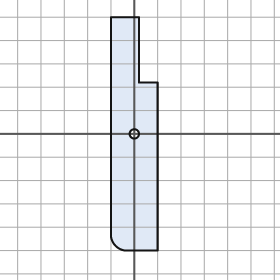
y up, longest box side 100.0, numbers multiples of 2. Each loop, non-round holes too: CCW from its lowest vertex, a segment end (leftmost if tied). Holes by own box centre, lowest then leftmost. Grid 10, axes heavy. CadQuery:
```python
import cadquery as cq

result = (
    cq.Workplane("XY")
    .moveTo(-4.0, -50.0)
    .lineTo(10.0, -50.0)
    .lineTo(10.0, 22.0)
    .lineTo(2.0, 22.0)
    .lineTo(2.0, 50.0)
    .lineTo(-10.0, 50.0)
    .lineTo(-10.0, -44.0)
    .threePointArc((-8.0, -48.0), (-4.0, -50.0))
    .close()
    .moveTo(0.0, 0.0)
    .circle(2.0)
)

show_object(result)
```